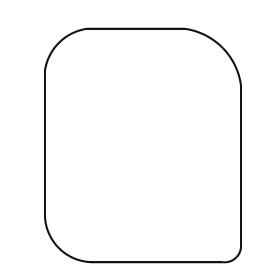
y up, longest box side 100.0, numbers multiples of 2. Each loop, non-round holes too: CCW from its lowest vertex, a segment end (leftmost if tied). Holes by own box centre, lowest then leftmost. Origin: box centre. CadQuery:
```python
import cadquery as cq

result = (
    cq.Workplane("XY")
    .moveTo(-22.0, -50.0)
    .lineTo(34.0, -50.0)
    .threePointArc((40.0, -48.0), (42.0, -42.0))
    .lineTo(42.0, 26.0)
    .threePointArc((34.0, 42.0), (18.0, 50.0))
    .lineTo(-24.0, 50.0)
    .threePointArc((-36.0, 44.0), (-42.0, 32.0))
    .lineTo(-42.0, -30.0)
    .threePointArc((-36.0, -44.0), (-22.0, -50.0))
    .close()
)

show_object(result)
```